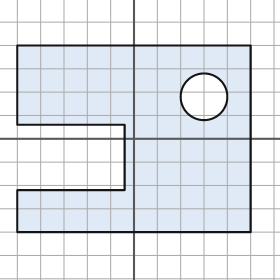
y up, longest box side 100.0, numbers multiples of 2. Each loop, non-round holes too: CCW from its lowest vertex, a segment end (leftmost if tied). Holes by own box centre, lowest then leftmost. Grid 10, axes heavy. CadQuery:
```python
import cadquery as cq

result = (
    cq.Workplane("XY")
    .moveTo(-50.0, -40.0)
    .lineTo(50.0, -40.0)
    .lineTo(50.0, 40.0)
    .lineTo(-50.0, 40.0)
    .lineTo(-50.0, 6.0)
    .lineTo(-4.0, 6.0)
    .lineTo(-4.0, -22.0)
    .lineTo(-50.0, -22.0)
    .close()
    .moveTo(30.0, 18.0)
    .circle(10.0)
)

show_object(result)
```